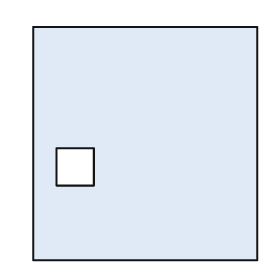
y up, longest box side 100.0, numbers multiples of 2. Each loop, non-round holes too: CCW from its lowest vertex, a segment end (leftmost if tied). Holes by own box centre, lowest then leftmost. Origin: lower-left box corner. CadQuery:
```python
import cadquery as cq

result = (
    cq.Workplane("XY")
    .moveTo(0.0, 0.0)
    .lineTo(96.0, 0.0)
    .lineTo(96.0, 100.0)
    .lineTo(0.0, 100.0)
    .close()
    .moveTo(10.0, 32.0)
    .lineTo(26.0, 32.0)
    .lineTo(26.0, 48.0)
    .lineTo(10.0, 48.0)
    .close()
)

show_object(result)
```